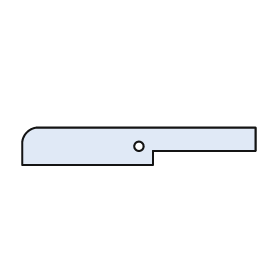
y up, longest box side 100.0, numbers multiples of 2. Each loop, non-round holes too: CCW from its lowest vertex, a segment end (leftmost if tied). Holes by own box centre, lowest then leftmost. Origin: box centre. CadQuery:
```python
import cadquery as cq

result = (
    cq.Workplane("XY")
    .moveTo(-50.0, -8.0)
    .lineTo(6.0, -8.0)
    .lineTo(6.0, -2.0)
    .lineTo(50.0, -2.0)
    .lineTo(50.0, 8.0)
    .lineTo(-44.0, 8.0)
    .threePointArc((-48.0, 6.0), (-50.0, 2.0))
    .close()
    .moveTo(0.0, 0.0)
    .circle(2.0)
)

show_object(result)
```